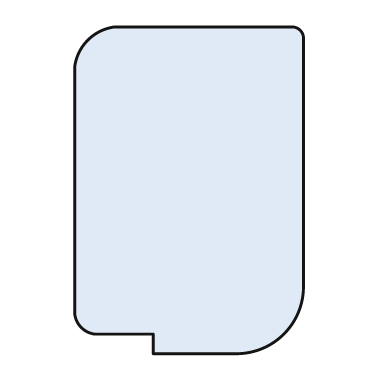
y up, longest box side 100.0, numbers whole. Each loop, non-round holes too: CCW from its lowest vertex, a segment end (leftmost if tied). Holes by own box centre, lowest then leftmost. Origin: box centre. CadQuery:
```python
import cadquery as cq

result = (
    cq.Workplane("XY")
    .moveTo(-11.0, -50.0)
    .lineTo(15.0, -50.0)
    .threePointArc((29.0, -44.0), (35.0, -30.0))
    .lineTo(35.0, 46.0)
    .threePointArc((34.0, 49.0), (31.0, 50.0))
    .lineTo(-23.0, 50.0)
    .threePointArc((-31.0, 46.0), (-35.0, 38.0))
    .lineTo(-35.0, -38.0)
    .threePointArc((-33.0, -42.0), (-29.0, -44.0))
    .lineTo(-11.0, -44.0)
    .close()
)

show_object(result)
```